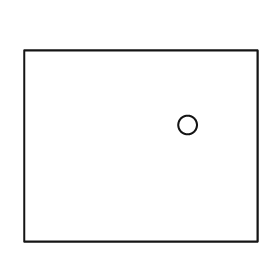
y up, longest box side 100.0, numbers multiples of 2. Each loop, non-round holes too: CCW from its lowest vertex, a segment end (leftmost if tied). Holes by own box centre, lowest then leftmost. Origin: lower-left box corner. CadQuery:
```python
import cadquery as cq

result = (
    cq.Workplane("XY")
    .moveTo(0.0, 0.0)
    .lineTo(100.0, 0.0)
    .lineTo(100.0, 82.0)
    .lineTo(0.0, 82.0)
    .close()
    .moveTo(70.0, 50.0)
    .circle(4.0)
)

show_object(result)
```